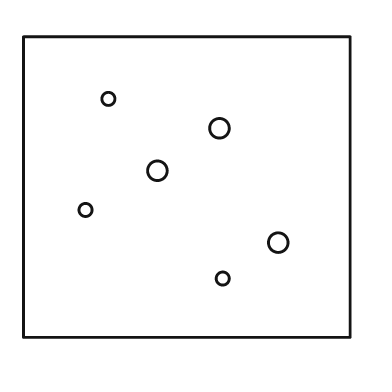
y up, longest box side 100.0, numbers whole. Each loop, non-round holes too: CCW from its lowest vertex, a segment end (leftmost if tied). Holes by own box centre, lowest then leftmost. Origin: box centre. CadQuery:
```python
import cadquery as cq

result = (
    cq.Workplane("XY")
    .moveTo(-50.0, -46.0)
    .lineTo(50.0, -46.0)
    .lineTo(50.0, 46.0)
    .lineTo(-50.0, 46.0)
    .close()
    .moveTo(11.0, -28.0)
    .circle(2.0)
    .moveTo(28.0, -17.0)
    .circle(3.0)
    .moveTo(-31.0, -7.0)
    .circle(2.0)
    .moveTo(-9.0, 5.0)
    .circle(3.0)
    .moveTo(10.0, 18.0)
    .circle(3.0)
    .moveTo(-24.0, 27.0)
    .circle(2.0)
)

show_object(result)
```